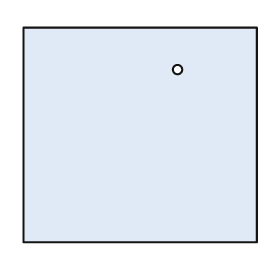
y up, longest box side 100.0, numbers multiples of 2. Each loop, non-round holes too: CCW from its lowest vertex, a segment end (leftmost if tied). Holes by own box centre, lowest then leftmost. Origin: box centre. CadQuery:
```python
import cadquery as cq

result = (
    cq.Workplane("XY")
    .moveTo(-50.0, -46.0)
    .lineTo(50.0, -46.0)
    .lineTo(50.0, 46.0)
    .lineTo(-50.0, 46.0)
    .close()
    .moveTo(16.0, 28.0)
    .circle(2.0)
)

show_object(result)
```